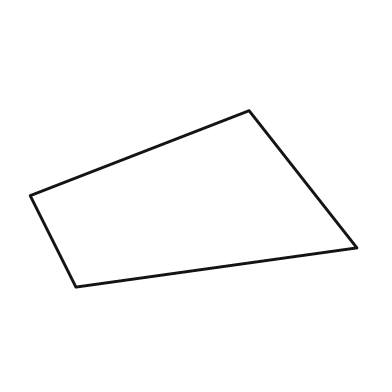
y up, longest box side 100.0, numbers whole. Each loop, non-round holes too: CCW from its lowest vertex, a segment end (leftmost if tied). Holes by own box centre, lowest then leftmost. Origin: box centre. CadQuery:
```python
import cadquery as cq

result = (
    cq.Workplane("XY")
    .moveTo(-36.0, -27.0)
    .lineTo(50.0, -15.0)
    .lineTo(17.0, 27.0)
    .lineTo(-50.0, 1.0)
    .close()
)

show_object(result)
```